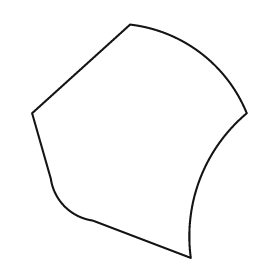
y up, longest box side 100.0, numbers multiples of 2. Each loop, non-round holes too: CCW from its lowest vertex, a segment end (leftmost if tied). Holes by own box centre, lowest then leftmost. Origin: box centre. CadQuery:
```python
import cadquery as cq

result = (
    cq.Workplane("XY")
    .moveTo(22.0, -50.0)
    .threePointArc((26.0, -16.0), (46.0, 12.0))
    .threePointArc((26.0, 38.0), (-4.0, 50.0))
    .lineTo(-46.0, 12.0)
    .lineTo(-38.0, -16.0)
    .threePointArc((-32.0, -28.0), (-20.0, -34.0))
    .close()
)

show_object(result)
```